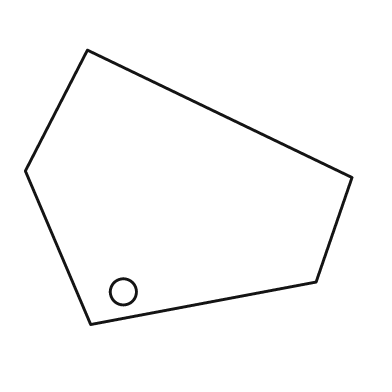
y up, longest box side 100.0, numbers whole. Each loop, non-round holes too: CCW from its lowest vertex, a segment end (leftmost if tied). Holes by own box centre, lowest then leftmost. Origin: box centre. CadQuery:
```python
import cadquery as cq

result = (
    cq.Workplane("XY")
    .moveTo(-30.0, -42.0)
    .lineTo(39.0, -29.0)
    .lineTo(50.0, 3.0)
    .lineTo(-31.0, 42.0)
    .lineTo(-50.0, 5.0)
    .close()
    .moveTo(-20.0, -32.0)
    .circle(4.0)
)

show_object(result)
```